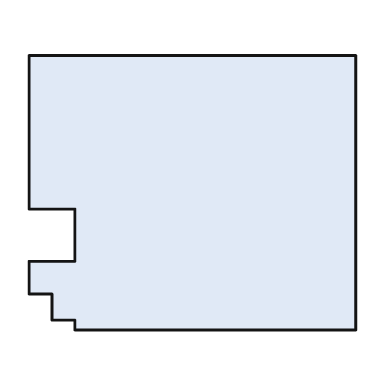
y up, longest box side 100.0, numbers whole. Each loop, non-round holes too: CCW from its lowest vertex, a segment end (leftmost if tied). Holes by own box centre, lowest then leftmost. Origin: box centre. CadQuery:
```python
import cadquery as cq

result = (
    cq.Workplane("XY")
    .moveTo(-36.0, -42.0)
    .lineTo(50.0, -42.0)
    .lineTo(50.0, 42.0)
    .lineTo(-50.0, 42.0)
    .lineTo(-50.0, -5.0)
    .lineTo(-36.0, -5.0)
    .lineTo(-36.0, -21.0)
    .lineTo(-50.0, -21.0)
    .lineTo(-50.0, -31.0)
    .lineTo(-43.0, -31.0)
    .lineTo(-43.0, -39.0)
    .lineTo(-36.0, -39.0)
    .close()
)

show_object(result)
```